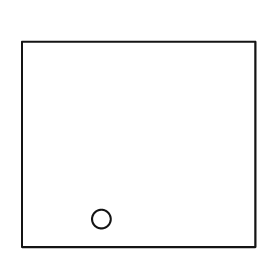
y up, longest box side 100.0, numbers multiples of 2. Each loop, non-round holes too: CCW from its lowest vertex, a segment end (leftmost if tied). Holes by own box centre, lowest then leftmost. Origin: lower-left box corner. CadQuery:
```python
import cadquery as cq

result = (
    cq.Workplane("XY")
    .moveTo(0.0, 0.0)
    .lineTo(100.0, 0.0)
    .lineTo(100.0, 88.0)
    .lineTo(0.0, 88.0)
    .close()
    .moveTo(34.0, 12.0)
    .circle(4.0)
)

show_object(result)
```